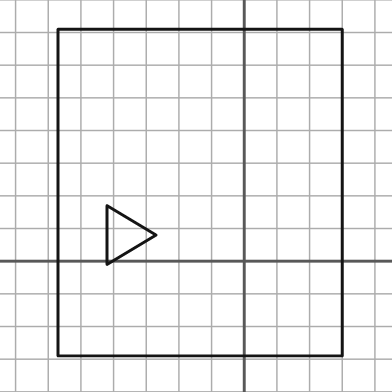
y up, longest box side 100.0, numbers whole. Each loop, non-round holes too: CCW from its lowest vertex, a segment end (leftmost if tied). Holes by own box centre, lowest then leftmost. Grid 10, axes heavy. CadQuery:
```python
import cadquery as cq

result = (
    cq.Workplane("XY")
    .moveTo(-57.0, -29.0)
    .lineTo(30.0, -29.0)
    .lineTo(30.0, 71.0)
    .lineTo(-57.0, 71.0)
    .close()
    .moveTo(-42.0, -1.0)
    .lineTo(-27.0, 8.0)
    .lineTo(-42.0, 17.0)
    .close()
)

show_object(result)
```